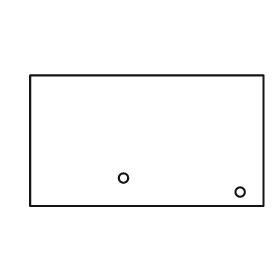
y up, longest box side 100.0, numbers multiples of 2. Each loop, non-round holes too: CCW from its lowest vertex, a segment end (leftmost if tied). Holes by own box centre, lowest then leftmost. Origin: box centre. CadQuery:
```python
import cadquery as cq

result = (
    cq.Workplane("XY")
    .moveTo(-50.0, -28.0)
    .lineTo(50.0, -28.0)
    .lineTo(50.0, 28.0)
    .lineTo(-50.0, 28.0)
    .close()
    .moveTo(40.0, -22.0)
    .circle(2.0)
    .moveTo(-10.0, -16.0)
    .circle(2.0)
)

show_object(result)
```